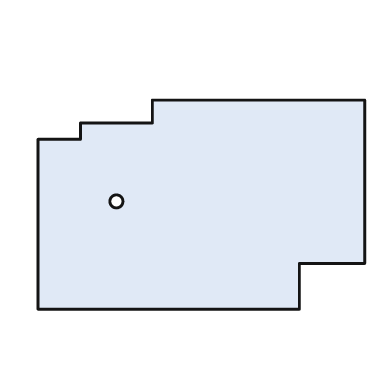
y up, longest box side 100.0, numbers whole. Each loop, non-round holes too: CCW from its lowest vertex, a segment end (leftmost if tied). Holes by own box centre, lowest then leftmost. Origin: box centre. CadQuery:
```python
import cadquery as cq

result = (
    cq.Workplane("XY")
    .moveTo(-50.0, -32.0)
    .lineTo(30.0, -32.0)
    .lineTo(30.0, -18.0)
    .lineTo(50.0, -18.0)
    .lineTo(50.0, 32.0)
    .lineTo(-15.0, 32.0)
    .lineTo(-15.0, 25.0)
    .lineTo(-37.0, 25.0)
    .lineTo(-37.0, 20.0)
    .lineTo(-50.0, 20.0)
    .close()
    .moveTo(-26.0, 1.0)
    .circle(2.0)
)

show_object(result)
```